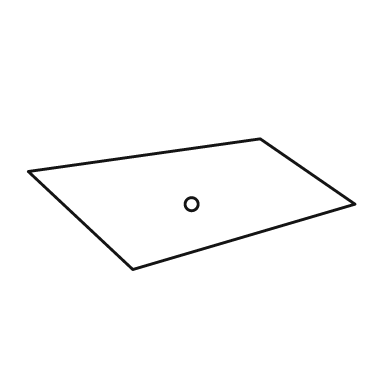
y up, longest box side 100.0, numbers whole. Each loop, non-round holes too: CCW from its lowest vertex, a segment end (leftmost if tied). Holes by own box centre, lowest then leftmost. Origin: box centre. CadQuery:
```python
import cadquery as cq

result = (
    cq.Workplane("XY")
    .moveTo(-18.0, -20.0)
    .lineTo(50.0, 0.0)
    .lineTo(21.0, 20.0)
    .lineTo(-50.0, 10.0)
    .close()
    .moveTo(0.0, 0.0)
    .circle(2.0)
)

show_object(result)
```